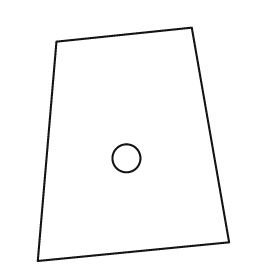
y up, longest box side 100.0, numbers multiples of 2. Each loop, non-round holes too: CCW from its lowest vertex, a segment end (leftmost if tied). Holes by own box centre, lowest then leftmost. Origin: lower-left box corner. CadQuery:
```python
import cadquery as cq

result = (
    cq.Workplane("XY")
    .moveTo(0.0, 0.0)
    .lineTo(82.0, 8.0)
    .lineTo(66.0, 100.0)
    .lineTo(8.0, 94.0)
    .close()
    .moveTo(38.0, 44.0)
    .circle(6.0)
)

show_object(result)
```